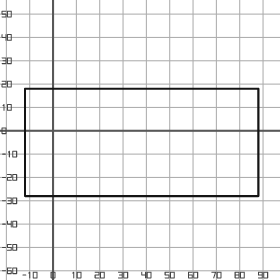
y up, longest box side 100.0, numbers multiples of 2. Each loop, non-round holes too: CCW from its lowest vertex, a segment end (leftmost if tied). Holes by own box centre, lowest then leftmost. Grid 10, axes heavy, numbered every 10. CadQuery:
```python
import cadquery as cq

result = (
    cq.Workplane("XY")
    .moveTo(-12.0, -28.0)
    .lineTo(88.0, -28.0)
    .lineTo(88.0, 18.0)
    .lineTo(-12.0, 18.0)
    .close()
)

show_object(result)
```